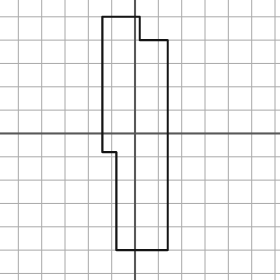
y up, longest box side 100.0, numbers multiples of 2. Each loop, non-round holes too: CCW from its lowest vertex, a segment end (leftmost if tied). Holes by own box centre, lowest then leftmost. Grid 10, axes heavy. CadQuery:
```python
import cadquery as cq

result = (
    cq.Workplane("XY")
    .moveTo(-8.0, -50.0)
    .lineTo(14.0, -50.0)
    .lineTo(14.0, 40.0)
    .lineTo(2.0, 40.0)
    .lineTo(2.0, 50.0)
    .lineTo(-14.0, 50.0)
    .lineTo(-14.0, -8.0)
    .lineTo(-8.0, -8.0)
    .close()
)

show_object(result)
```